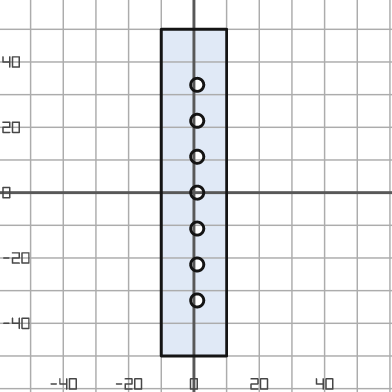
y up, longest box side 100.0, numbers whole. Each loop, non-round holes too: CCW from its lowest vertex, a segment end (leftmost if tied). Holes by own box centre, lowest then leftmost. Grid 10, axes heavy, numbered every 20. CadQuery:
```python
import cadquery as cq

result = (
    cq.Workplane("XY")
    .moveTo(-10.0, -50.0)
    .lineTo(10.0, -50.0)
    .lineTo(10.0, 50.0)
    .lineTo(-10.0, 50.0)
    .close()
    .moveTo(1.0, -33.0)
    .circle(2.0)
    .moveTo(1.0, -22.0)
    .circle(2.0)
    .moveTo(1.0, -11.0)
    .circle(2.0)
    .moveTo(1.0, 0.0)
    .circle(2.0)
    .moveTo(1.0, 11.0)
    .circle(2.0)
    .moveTo(1.0, 22.0)
    .circle(2.0)
    .moveTo(1.0, 33.0)
    .circle(2.0)
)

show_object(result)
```